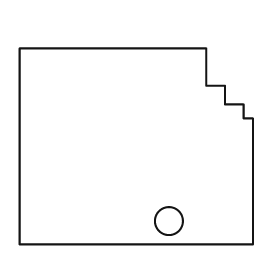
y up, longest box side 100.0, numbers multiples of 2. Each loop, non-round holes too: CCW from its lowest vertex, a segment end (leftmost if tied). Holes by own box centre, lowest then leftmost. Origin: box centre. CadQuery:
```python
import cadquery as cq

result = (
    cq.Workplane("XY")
    .moveTo(-50.0, -42.0)
    .lineTo(50.0, -42.0)
    .lineTo(50.0, 12.0)
    .lineTo(46.0, 12.0)
    .lineTo(46.0, 18.0)
    .lineTo(38.0, 18.0)
    .lineTo(38.0, 26.0)
    .lineTo(30.0, 26.0)
    .lineTo(30.0, 42.0)
    .lineTo(-50.0, 42.0)
    .close()
    .moveTo(14.0, -32.0)
    .circle(6.0)
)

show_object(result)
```